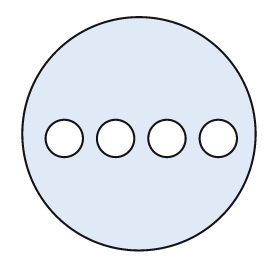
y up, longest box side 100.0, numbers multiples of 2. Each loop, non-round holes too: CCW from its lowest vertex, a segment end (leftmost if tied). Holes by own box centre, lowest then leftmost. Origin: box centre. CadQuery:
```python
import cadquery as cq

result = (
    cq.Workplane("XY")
    .moveTo(0.0, 0.0)
    .circle(50.0)
    .moveTo(-32.0, -2.0)
    .circle(8.0)
    .moveTo(-10.0, -2.0)
    .circle(8.0)
    .moveTo(12.0, -2.0)
    .circle(8.0)
    .moveTo(34.0, -2.0)
    .circle(8.0)
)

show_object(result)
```